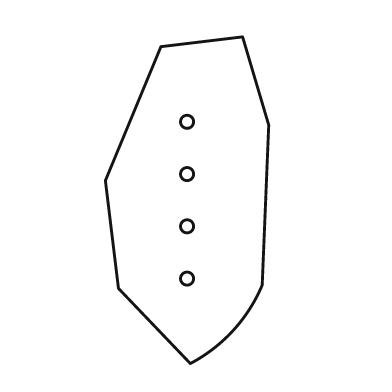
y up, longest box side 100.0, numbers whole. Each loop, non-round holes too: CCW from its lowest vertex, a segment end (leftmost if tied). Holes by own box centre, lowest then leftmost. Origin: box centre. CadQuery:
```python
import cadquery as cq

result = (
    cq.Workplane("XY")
    .moveTo(1.0, -50.0)
    .threePointArc((14.0, -40.0), (23.0, -26.0))
    .lineTo(25.0, 23.0)
    .lineTo(17.0, 50.0)
    .lineTo(-8.0, 47.0)
    .lineTo(-25.0, 6.0)
    .lineTo(-21.0, -27.0)
    .close()
    .moveTo(0.0, -24.0)
    .circle(2.0)
    .moveTo(0.0, -8.0)
    .circle(2.0)
    .moveTo(0.0, 8.0)
    .circle(2.0)
    .moveTo(0.0, 24.0)
    .circle(2.0)
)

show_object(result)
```